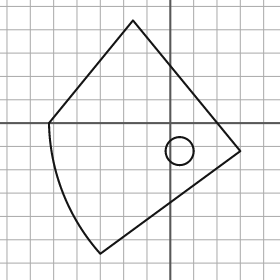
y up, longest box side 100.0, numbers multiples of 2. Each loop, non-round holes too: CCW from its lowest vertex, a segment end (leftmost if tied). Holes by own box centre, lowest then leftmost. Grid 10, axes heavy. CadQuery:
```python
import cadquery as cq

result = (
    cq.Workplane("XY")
    .moveTo(-30.0, -56.0)
    .lineTo(30.0, -12.0)
    .lineTo(-16.0, 44.0)
    .lineTo(-52.0, 0.0)
    .threePointArc((-46.0, -30.0), (-30.0, -56.0))
    .close()
    .moveTo(4.0, -12.0)
    .circle(6.0)
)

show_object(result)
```